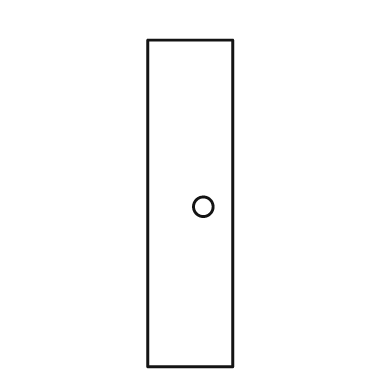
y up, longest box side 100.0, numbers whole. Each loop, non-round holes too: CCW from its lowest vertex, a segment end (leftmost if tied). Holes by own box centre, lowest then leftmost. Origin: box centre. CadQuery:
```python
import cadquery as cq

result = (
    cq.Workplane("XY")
    .moveTo(-13.0, -50.0)
    .lineTo(13.0, -50.0)
    .lineTo(13.0, 50.0)
    .lineTo(-13.0, 50.0)
    .close()
    .moveTo(4.0, -1.0)
    .circle(3.0)
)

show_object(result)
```